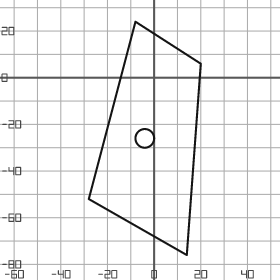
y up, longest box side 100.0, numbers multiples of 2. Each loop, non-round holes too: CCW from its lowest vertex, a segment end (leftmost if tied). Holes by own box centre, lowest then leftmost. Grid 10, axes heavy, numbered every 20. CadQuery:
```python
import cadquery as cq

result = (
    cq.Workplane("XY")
    .moveTo(14.0, -76.0)
    .lineTo(20.0, 6.0)
    .lineTo(-8.0, 24.0)
    .lineTo(-28.0, -52.0)
    .close()
    .moveTo(-4.0, -26.0)
    .circle(4.0)
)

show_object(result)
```